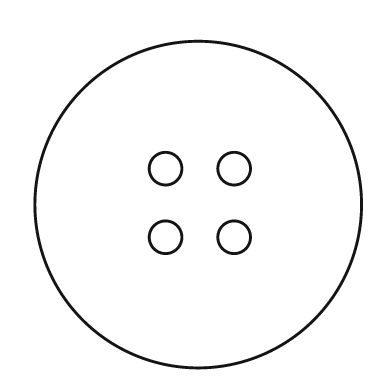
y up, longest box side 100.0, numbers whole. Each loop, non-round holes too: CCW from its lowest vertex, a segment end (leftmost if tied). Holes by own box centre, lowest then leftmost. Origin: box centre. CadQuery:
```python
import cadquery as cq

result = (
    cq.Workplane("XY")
    .moveTo(0.0, 0.0)
    .circle(50.0)
    .moveTo(-10.0, -10.0)
    .circle(5.0)
    .moveTo(11.0, -10.0)
    .circle(5.0)
    .moveTo(-10.0, 11.0)
    .circle(5.0)
    .moveTo(11.0, 11.0)
    .circle(5.0)
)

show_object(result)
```